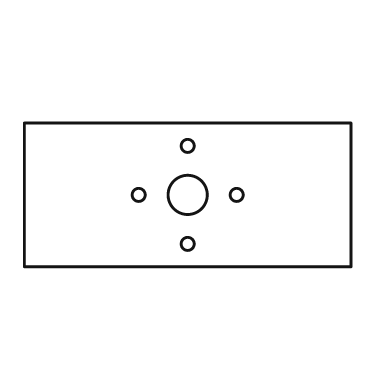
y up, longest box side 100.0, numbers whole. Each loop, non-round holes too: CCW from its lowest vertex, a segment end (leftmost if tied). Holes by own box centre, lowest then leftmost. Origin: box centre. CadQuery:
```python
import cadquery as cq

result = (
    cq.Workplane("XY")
    .moveTo(-50.0, -22.0)
    .lineTo(50.0, -22.0)
    .lineTo(50.0, 22.0)
    .lineTo(-50.0, 22.0)
    .close()
    .moveTo(0.0, -15.0)
    .circle(2.0)
    .moveTo(-15.0, 0.0)
    .circle(2.0)
    .moveTo(0.0, 0.0)
    .circle(6.0)
    .moveTo(15.0, 0.0)
    .circle(2.0)
    .moveTo(0.0, 15.0)
    .circle(2.0)
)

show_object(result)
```